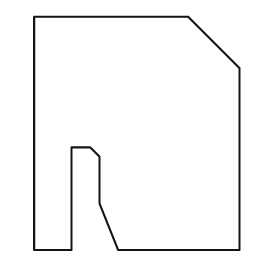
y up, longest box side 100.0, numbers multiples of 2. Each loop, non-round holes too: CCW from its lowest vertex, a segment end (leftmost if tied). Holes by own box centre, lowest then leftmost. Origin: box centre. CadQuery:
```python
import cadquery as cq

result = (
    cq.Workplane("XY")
    .moveTo(-44.0, -50.0)
    .lineTo(-28.0, -50.0)
    .lineTo(-28.0, -6.0)
    .lineTo(-20.0, -6.0)
    .lineTo(-16.0, -10.0)
    .lineTo(-16.0, -30.0)
    .lineTo(-8.0, -50.0)
    .lineTo(44.0, -50.0)
    .lineTo(44.0, 28.0)
    .lineTo(22.0, 50.0)
    .lineTo(-44.0, 50.0)
    .close()
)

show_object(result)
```